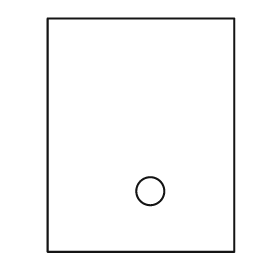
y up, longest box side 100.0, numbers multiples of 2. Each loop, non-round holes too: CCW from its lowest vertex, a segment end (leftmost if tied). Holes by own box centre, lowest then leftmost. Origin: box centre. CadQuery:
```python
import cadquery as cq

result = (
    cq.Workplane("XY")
    .moveTo(-40.0, -50.0)
    .lineTo(40.0, -50.0)
    .lineTo(40.0, 50.0)
    .lineTo(-40.0, 50.0)
    .close()
    .moveTo(4.0, -24.0)
    .circle(6.0)
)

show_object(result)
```